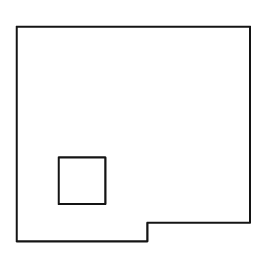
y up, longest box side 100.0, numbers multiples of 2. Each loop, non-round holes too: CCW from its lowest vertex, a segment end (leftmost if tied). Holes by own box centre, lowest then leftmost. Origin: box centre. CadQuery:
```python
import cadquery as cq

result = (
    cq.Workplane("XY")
    .moveTo(-50.0, -46.0)
    .lineTo(6.0, -46.0)
    .lineTo(6.0, -38.0)
    .lineTo(50.0, -38.0)
    .lineTo(50.0, 46.0)
    .lineTo(-50.0, 46.0)
    .close()
    .moveTo(-32.0, -30.0)
    .lineTo(-12.0, -30.0)
    .lineTo(-12.0, -10.0)
    .lineTo(-32.0, -10.0)
    .close()
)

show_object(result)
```